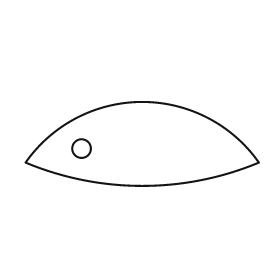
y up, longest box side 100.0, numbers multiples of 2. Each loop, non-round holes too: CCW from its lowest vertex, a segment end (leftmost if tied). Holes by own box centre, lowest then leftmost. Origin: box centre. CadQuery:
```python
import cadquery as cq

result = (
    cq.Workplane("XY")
    .moveTo(-50.0, -8.0)
    .threePointArc((0.0, -18.0), (50.0, -8.0))
    .threePointArc((0.0, 18.0), (-50.0, -8.0))
    .close()
    .moveTo(-26.0, -2.0)
    .circle(4.0)
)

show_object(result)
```